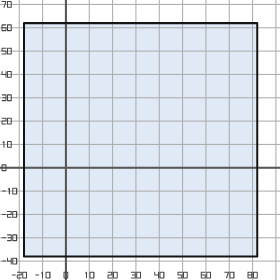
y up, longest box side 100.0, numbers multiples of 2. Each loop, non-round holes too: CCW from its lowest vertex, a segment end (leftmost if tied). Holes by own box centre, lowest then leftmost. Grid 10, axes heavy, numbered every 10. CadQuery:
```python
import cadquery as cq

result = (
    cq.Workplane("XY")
    .moveTo(-18.0, -38.0)
    .lineTo(82.0, -38.0)
    .lineTo(82.0, 62.0)
    .lineTo(-18.0, 62.0)
    .close()
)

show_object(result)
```